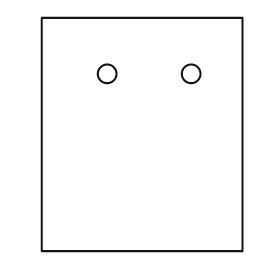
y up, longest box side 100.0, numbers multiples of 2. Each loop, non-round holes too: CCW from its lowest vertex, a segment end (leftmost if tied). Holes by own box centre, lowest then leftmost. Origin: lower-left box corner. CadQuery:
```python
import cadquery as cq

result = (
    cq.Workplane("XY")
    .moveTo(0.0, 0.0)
    .lineTo(86.0, 0.0)
    .lineTo(86.0, 100.0)
    .lineTo(0.0, 100.0)
    .close()
    .moveTo(28.0, 76.0)
    .circle(4.0)
    .moveTo(64.0, 76.0)
    .circle(4.0)
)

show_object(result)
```